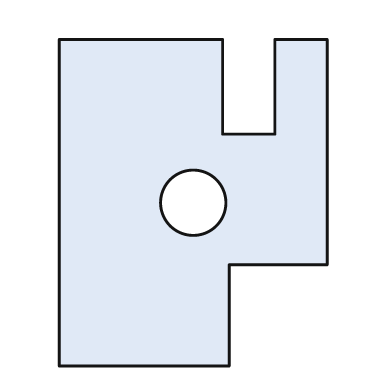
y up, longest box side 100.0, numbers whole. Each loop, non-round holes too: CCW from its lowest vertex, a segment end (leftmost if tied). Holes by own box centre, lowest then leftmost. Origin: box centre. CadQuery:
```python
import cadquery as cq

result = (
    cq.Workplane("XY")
    .moveTo(-41.0, -50.0)
    .lineTo(11.0, -50.0)
    .lineTo(11.0, -19.0)
    .lineTo(41.0, -19.0)
    .lineTo(41.0, 50.0)
    .lineTo(25.0, 50.0)
    .lineTo(25.0, 21.0)
    .lineTo(9.0, 21.0)
    .lineTo(9.0, 50.0)
    .lineTo(-41.0, 50.0)
    .close()
    .moveTo(0.0, 0.0)
    .circle(10.0)
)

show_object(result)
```